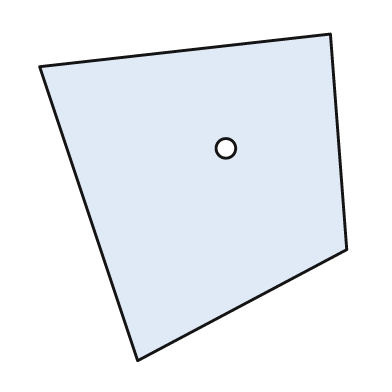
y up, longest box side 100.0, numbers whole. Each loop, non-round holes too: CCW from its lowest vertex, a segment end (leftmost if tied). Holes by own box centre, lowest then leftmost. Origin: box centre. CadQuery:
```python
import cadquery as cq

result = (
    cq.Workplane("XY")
    .moveTo(-17.0, -50.0)
    .lineTo(47.0, -16.0)
    .lineTo(42.0, 50.0)
    .lineTo(-47.0, 40.0)
    .close()
    .moveTo(10.0, 15.0)
    .circle(3.0)
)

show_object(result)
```